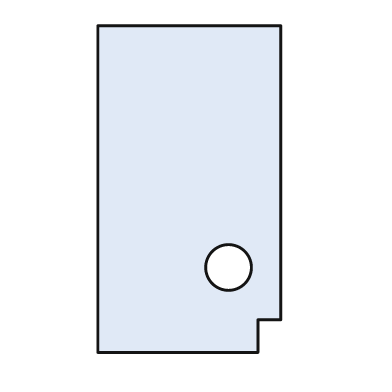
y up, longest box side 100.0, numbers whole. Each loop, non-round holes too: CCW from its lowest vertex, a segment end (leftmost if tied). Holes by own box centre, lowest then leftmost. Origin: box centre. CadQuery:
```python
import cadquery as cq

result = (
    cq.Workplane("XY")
    .moveTo(-28.0, -50.0)
    .lineTo(21.0, -50.0)
    .lineTo(21.0, -40.0)
    .lineTo(28.0, -40.0)
    .lineTo(28.0, 50.0)
    .lineTo(-28.0, 50.0)
    .close()
    .moveTo(12.0, -24.0)
    .circle(7.0)
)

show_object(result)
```